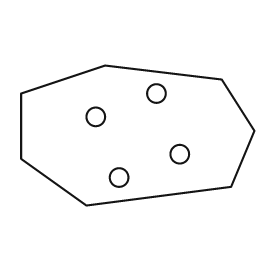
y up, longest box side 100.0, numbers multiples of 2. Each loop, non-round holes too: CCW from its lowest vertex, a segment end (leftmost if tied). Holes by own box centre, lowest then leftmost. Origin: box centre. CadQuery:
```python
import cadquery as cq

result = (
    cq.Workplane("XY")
    .moveTo(-22.0, -30.0)
    .lineTo(40.0, -22.0)
    .lineTo(50.0, 2.0)
    .lineTo(36.0, 24.0)
    .lineTo(-14.0, 30.0)
    .lineTo(-50.0, 18.0)
    .lineTo(-50.0, -10.0)
    .close()
    .moveTo(-8.0, -18.0)
    .circle(4.0)
    .moveTo(18.0, -8.0)
    .circle(4.0)
    .moveTo(-18.0, 8.0)
    .circle(4.0)
    .moveTo(8.0, 18.0)
    .circle(4.0)
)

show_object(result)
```